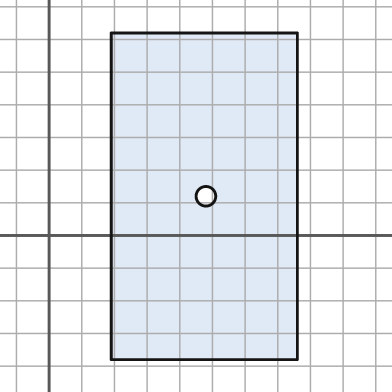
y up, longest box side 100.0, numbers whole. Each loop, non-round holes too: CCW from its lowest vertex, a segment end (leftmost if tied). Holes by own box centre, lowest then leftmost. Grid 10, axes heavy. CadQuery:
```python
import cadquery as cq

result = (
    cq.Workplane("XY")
    .moveTo(19.0, -38.0)
    .lineTo(76.0, -38.0)
    .lineTo(76.0, 62.0)
    .lineTo(19.0, 62.0)
    .close()
    .moveTo(48.0, 12.0)
    .circle(3.0)
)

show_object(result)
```